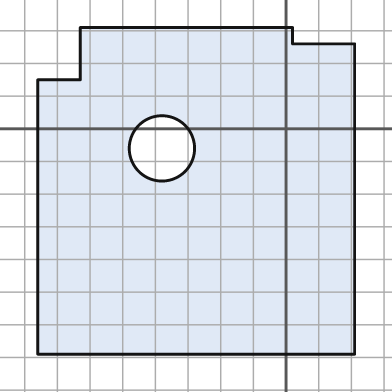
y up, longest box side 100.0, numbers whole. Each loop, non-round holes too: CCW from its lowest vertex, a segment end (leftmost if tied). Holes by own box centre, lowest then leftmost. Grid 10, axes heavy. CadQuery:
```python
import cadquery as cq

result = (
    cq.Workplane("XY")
    .moveTo(-76.0, -69.0)
    .lineTo(21.0, -69.0)
    .lineTo(21.0, 26.0)
    .lineTo(2.0, 26.0)
    .lineTo(2.0, 31.0)
    .lineTo(-63.0, 31.0)
    .lineTo(-63.0, 15.0)
    .lineTo(-76.0, 15.0)
    .close()
    .moveTo(-38.0, -6.0)
    .circle(10.0)
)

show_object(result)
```